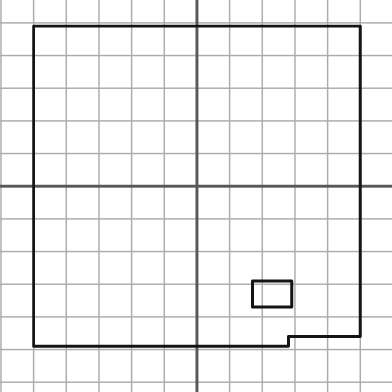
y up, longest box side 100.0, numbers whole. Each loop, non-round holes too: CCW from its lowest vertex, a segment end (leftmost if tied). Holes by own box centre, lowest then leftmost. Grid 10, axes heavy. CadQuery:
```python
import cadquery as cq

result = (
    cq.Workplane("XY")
    .moveTo(-50.0, -49.0)
    .lineTo(28.0, -49.0)
    .lineTo(28.0, -46.0)
    .lineTo(50.0, -46.0)
    .lineTo(50.0, 49.0)
    .lineTo(-50.0, 49.0)
    .close()
    .moveTo(17.0, -37.0)
    .lineTo(29.0, -37.0)
    .lineTo(29.0, -29.0)
    .lineTo(17.0, -29.0)
    .close()
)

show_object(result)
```